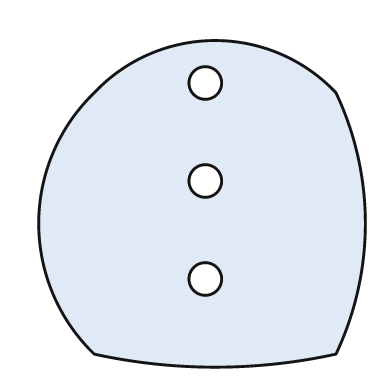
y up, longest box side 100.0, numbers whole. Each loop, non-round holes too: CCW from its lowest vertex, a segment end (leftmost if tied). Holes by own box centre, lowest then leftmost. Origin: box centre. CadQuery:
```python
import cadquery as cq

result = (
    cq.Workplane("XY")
    .moveTo(-33.0, -46.0)
    .threePointArc((4.0, -50.0), (41.0, -46.0))
    .threePointArc((50.0, -6.0), (41.0, 34.0))
    .threePointArc((4.0, 50.0), (-33.0, 34.0))
    .threePointArc((-50.0, -6.0), (-33.0, -46.0))
    .close()
    .moveTo(1.0, -23.0)
    .circle(5.0)
    .moveTo(1.0, 7.0)
    .circle(5.0)
    .moveTo(1.0, 37.0)
    .circle(5.0)
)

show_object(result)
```